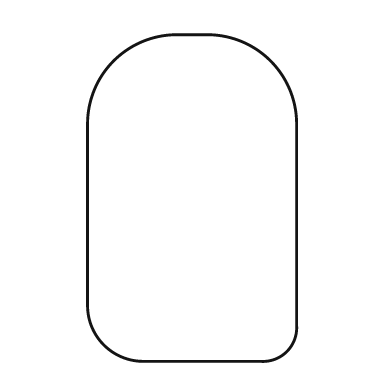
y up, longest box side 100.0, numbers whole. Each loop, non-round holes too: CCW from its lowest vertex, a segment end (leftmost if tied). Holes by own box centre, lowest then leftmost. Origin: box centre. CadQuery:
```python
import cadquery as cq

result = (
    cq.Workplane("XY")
    .moveTo(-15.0, -50.0)
    .lineTo(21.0, -50.0)
    .threePointArc((29.0, -47.0), (32.0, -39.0))
    .lineTo(32.0, 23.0)
    .threePointArc((24.0, 42.0), (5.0, 50.0))
    .lineTo(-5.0, 50.0)
    .threePointArc((-24.0, 42.0), (-32.0, 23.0))
    .lineTo(-32.0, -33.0)
    .threePointArc((-27.0, -45.0), (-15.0, -50.0))
    .close()
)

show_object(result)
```